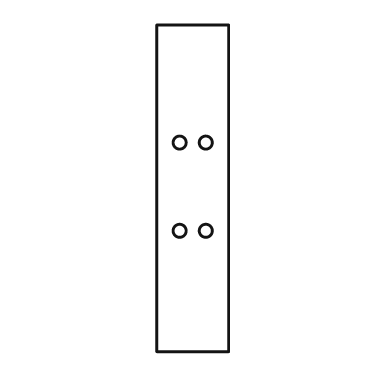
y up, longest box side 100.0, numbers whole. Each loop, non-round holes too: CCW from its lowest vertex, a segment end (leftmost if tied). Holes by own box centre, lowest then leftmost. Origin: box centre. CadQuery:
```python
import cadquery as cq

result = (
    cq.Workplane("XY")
    .moveTo(-11.0, -50.0)
    .lineTo(11.0, -50.0)
    .lineTo(11.0, 50.0)
    .lineTo(-11.0, 50.0)
    .close()
    .moveTo(-4.0, -13.0)
    .circle(2.0)
    .moveTo(4.0, -13.0)
    .circle(2.0)
    .moveTo(-4.0, 14.0)
    .circle(2.0)
    .moveTo(4.0, 14.0)
    .circle(2.0)
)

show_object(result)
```